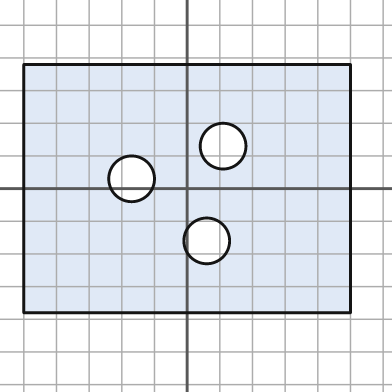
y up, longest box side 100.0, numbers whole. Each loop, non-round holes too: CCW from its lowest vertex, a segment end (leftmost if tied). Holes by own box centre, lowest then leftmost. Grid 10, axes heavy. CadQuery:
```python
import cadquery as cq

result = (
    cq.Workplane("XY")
    .moveTo(-50.0, -38.0)
    .lineTo(50.0, -38.0)
    .lineTo(50.0, 38.0)
    .lineTo(-50.0, 38.0)
    .close()
    .moveTo(6.0, -16.0)
    .circle(7.0)
    .moveTo(-17.0, 3.0)
    .circle(7.0)
    .moveTo(11.0, 13.0)
    .circle(7.0)
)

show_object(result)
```